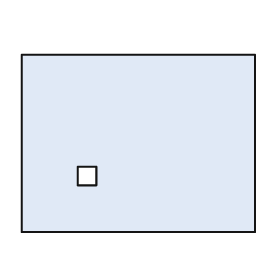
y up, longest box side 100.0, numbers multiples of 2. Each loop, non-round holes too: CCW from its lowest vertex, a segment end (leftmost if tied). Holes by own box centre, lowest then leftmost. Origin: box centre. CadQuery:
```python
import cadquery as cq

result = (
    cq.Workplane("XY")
    .moveTo(-50.0, -38.0)
    .lineTo(50.0, -38.0)
    .lineTo(50.0, 38.0)
    .lineTo(-50.0, 38.0)
    .close()
    .moveTo(-26.0, -18.0)
    .lineTo(-18.0, -18.0)
    .lineTo(-18.0, -10.0)
    .lineTo(-26.0, -10.0)
    .close()
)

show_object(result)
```